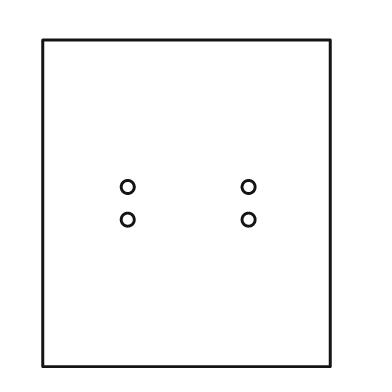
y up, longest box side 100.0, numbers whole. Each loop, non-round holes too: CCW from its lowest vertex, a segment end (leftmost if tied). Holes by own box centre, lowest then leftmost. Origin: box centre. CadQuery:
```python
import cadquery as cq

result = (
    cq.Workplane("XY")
    .moveTo(-44.0, -50.0)
    .lineTo(44.0, -50.0)
    .lineTo(44.0, 50.0)
    .lineTo(-44.0, 50.0)
    .close()
    .moveTo(-18.0, -5.0)
    .circle(2.0)
    .moveTo(19.0, -5.0)
    .circle(2.0)
    .moveTo(-18.0, 5.0)
    .circle(2.0)
    .moveTo(19.0, 5.0)
    .circle(2.0)
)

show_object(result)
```